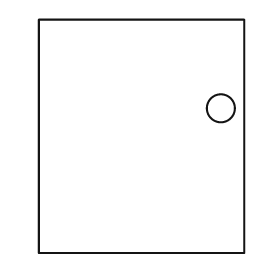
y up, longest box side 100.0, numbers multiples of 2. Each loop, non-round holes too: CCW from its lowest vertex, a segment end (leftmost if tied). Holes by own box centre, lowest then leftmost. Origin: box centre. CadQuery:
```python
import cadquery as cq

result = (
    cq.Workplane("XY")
    .moveTo(-44.0, -50.0)
    .lineTo(44.0, -50.0)
    .lineTo(44.0, 50.0)
    .lineTo(-44.0, 50.0)
    .close()
    .moveTo(34.0, 12.0)
    .circle(6.0)
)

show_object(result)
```